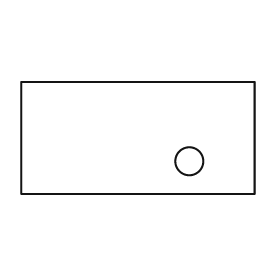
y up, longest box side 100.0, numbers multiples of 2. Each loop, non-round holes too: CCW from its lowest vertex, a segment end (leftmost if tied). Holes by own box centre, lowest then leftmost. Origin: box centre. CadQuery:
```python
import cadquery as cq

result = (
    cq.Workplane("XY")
    .moveTo(-50.0, -24.0)
    .lineTo(50.0, -24.0)
    .lineTo(50.0, 24.0)
    .lineTo(-50.0, 24.0)
    .close()
    .moveTo(22.0, -10.0)
    .circle(6.0)
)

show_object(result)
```